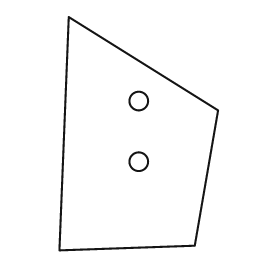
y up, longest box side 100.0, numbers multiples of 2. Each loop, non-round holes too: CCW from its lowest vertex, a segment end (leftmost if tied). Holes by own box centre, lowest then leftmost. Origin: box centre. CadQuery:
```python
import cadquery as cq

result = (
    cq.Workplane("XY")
    .moveTo(-34.0, -50.0)
    .lineTo(24.0, -48.0)
    .lineTo(34.0, 10.0)
    .lineTo(-30.0, 50.0)
    .close()
    .moveTo(0.0, -12.0)
    .circle(4.0)
    .moveTo(0.0, 14.0)
    .circle(4.0)
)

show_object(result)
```